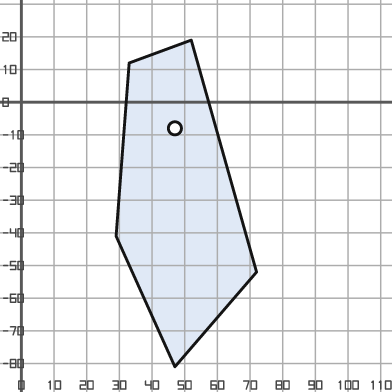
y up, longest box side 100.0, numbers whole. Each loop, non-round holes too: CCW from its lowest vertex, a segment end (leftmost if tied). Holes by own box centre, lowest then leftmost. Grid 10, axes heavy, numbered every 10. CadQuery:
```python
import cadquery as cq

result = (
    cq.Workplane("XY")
    .moveTo(47.0, -81.0)
    .lineTo(72.0, -52.0)
    .lineTo(52.0, 19.0)
    .lineTo(33.0, 12.0)
    .lineTo(29.0, -41.0)
    .close()
    .moveTo(47.0, -8.0)
    .circle(2.0)
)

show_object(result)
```